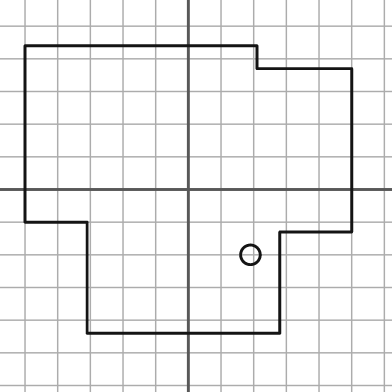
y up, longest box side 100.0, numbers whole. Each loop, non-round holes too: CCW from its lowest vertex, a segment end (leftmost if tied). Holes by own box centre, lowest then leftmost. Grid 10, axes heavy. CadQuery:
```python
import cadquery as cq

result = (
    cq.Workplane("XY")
    .moveTo(-31.0, -44.0)
    .lineTo(28.0, -44.0)
    .lineTo(28.0, -13.0)
    .lineTo(50.0, -13.0)
    .lineTo(50.0, 37.0)
    .lineTo(21.0, 37.0)
    .lineTo(21.0, 44.0)
    .lineTo(-50.0, 44.0)
    .lineTo(-50.0, -10.0)
    .lineTo(-31.0, -10.0)
    .close()
    .moveTo(19.0, -20.0)
    .circle(3.0)
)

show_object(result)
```